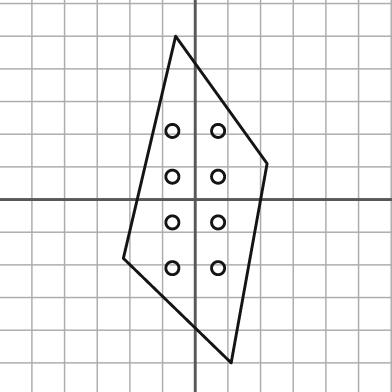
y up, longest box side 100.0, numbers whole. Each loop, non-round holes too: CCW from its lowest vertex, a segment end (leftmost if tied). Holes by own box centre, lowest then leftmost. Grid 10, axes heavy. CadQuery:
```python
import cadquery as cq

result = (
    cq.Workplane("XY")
    .moveTo(11.0, -50.0)
    .lineTo(22.0, 11.0)
    .lineTo(-6.0, 50.0)
    .lineTo(-22.0, -18.0)
    .close()
    .moveTo(-7.0, -21.0)
    .circle(2.0)
    .moveTo(7.0, -21.0)
    .circle(2.0)
    .moveTo(-7.0, -7.0)
    .circle(2.0)
    .moveTo(7.0, -7.0)
    .circle(2.0)
    .moveTo(-7.0, 7.0)
    .circle(2.0)
    .moveTo(7.0, 7.0)
    .circle(2.0)
    .moveTo(-7.0, 21.0)
    .circle(2.0)
    .moveTo(7.0, 21.0)
    .circle(2.0)
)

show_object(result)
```